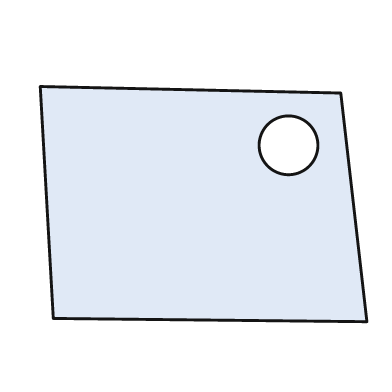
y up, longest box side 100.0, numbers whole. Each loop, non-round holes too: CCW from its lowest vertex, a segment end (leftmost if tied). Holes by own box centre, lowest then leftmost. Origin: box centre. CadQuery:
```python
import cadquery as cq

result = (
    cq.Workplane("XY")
    .moveTo(50.0, -36.0)
    .lineTo(42.0, 34.0)
    .lineTo(-50.0, 36.0)
    .lineTo(-46.0, -35.0)
    .close()
    .moveTo(26.0, 18.0)
    .circle(9.0)
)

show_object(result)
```